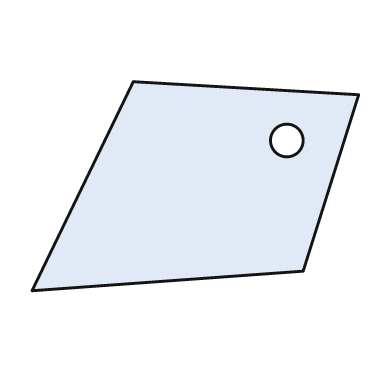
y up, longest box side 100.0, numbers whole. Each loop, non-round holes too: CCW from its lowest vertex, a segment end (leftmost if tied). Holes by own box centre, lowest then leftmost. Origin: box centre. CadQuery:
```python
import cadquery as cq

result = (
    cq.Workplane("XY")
    .moveTo(-50.0, -32.0)
    .lineTo(33.0, -26.0)
    .lineTo(50.0, 28.0)
    .lineTo(-19.0, 32.0)
    .close()
    .moveTo(28.0, 14.0)
    .circle(5.0)
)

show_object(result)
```